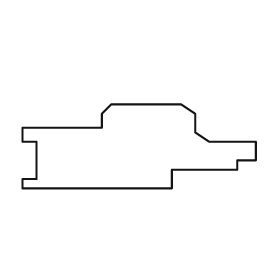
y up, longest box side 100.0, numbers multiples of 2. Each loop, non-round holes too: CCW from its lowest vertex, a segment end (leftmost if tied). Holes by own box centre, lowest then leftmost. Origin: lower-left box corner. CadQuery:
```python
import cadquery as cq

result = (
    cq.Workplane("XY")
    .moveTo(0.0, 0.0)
    .lineTo(64.0, 0.0)
    .lineTo(64.0, 8.0)
    .lineTo(92.0, 8.0)
    .lineTo(92.0, 12.0)
    .lineTo(100.0, 12.0)
    .lineTo(100.0, 20.0)
    .lineTo(80.0, 20.0)
    .lineTo(74.0, 24.0)
    .lineTo(74.0, 32.0)
    .lineTo(68.0, 36.0)
    .lineTo(38.0, 36.0)
    .lineTo(34.0, 32.0)
    .lineTo(34.0, 26.0)
    .lineTo(0.0, 26.0)
    .lineTo(0.0, 20.0)
    .lineTo(6.0, 20.0)
    .lineTo(6.0, 4.0)
    .lineTo(0.0, 4.0)
    .close()
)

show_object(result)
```